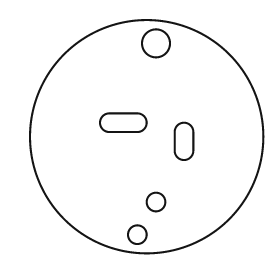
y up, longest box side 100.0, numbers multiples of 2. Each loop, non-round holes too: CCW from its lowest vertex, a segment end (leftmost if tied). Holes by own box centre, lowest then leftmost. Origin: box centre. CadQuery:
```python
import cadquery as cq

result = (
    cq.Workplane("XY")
    .moveTo(0.0, 0.0)
    .circle(50.0)
    .moveTo(-4.0, -42.0)
    .circle(4.0)
    .moveTo(4.0, -28.0)
    .circle(4.0)
    .moveTo(12.0, -6.0)
    .threePointArc((16.0, -10.0), (20.0, -6.0))
    .lineTo(20.0, 2.0)
    .threePointArc((16.0, 6.0), (12.0, 2.0))
    .close()
    .moveTo(-16.0, 2.0)
    .lineTo(-4.0, 2.0)
    .threePointArc((0.0, 6.0), (-4.0, 10.0))
    .lineTo(-16.0, 10.0)
    .threePointArc((-20.0, 6.0), (-16.0, 2.0))
    .close()
    .moveTo(4.0, 40.0)
    .circle(6.0)
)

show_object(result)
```